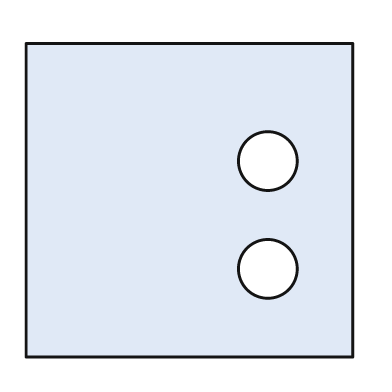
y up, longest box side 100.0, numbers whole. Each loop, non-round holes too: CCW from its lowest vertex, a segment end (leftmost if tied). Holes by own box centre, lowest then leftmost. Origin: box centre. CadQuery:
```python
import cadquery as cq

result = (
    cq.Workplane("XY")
    .moveTo(-50.0, -48.0)
    .lineTo(50.0, -48.0)
    .lineTo(50.0, 48.0)
    .lineTo(-50.0, 48.0)
    .close()
    .moveTo(24.0, -21.0)
    .circle(9.0)
    .moveTo(24.0, 12.0)
    .circle(9.0)
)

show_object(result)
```